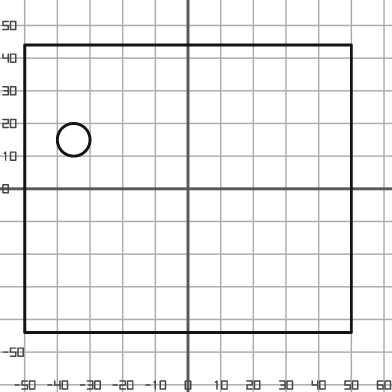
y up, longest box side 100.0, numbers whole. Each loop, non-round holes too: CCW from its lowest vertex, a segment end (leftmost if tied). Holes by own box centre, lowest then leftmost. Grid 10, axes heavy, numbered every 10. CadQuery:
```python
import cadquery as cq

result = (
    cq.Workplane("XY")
    .moveTo(-50.0, -44.0)
    .lineTo(50.0, -44.0)
    .lineTo(50.0, 44.0)
    .lineTo(-50.0, 44.0)
    .close()
    .moveTo(-35.0, 15.0)
    .circle(5.0)
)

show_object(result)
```